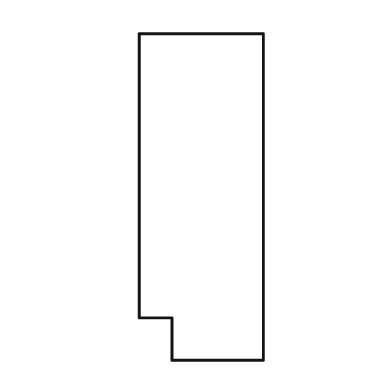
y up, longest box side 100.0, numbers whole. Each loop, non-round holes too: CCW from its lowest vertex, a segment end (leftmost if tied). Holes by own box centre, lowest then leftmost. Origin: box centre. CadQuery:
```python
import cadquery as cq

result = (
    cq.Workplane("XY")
    .moveTo(-9.0, -50.0)
    .lineTo(19.0, -50.0)
    .lineTo(19.0, 50.0)
    .lineTo(-19.0, 50.0)
    .lineTo(-19.0, -37.0)
    .lineTo(-9.0, -37.0)
    .close()
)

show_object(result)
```